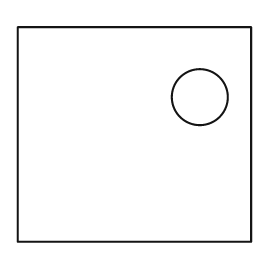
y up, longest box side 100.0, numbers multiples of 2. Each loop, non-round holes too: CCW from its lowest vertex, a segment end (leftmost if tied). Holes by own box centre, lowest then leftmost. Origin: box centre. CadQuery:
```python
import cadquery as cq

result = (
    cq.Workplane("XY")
    .moveTo(-50.0, -46.0)
    .lineTo(50.0, -46.0)
    .lineTo(50.0, 46.0)
    .lineTo(-50.0, 46.0)
    .close()
    .moveTo(28.0, 16.0)
    .circle(12.0)
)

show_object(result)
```